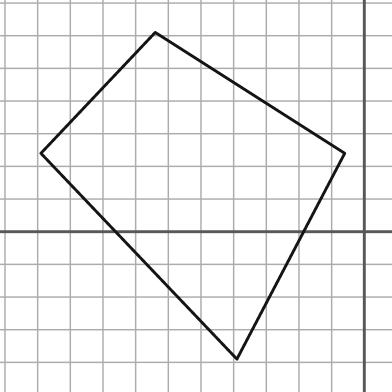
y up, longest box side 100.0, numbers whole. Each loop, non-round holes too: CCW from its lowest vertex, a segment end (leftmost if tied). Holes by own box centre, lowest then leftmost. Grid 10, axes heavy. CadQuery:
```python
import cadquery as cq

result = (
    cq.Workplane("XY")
    .moveTo(-39.0, -39.0)
    .lineTo(-6.0, 24.0)
    .lineTo(-64.0, 61.0)
    .lineTo(-99.0, 24.0)
    .close()
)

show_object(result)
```